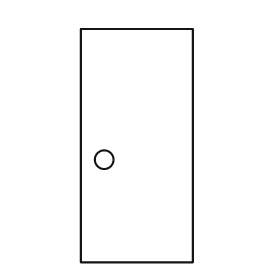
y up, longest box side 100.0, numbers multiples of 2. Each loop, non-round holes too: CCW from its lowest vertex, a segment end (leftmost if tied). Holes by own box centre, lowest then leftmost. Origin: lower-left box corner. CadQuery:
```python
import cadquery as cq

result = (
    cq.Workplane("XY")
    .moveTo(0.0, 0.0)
    .lineTo(48.0, 0.0)
    .lineTo(48.0, 100.0)
    .lineTo(0.0, 100.0)
    .close()
    .moveTo(10.0, 44.0)
    .circle(4.0)
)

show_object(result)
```